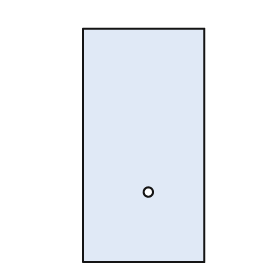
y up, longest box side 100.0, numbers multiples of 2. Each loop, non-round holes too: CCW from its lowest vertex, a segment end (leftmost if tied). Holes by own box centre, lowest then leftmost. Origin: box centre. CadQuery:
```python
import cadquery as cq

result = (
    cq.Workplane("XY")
    .moveTo(-26.0, -50.0)
    .lineTo(26.0, -50.0)
    .lineTo(26.0, 50.0)
    .lineTo(-26.0, 50.0)
    .close()
    .moveTo(2.0, -20.0)
    .circle(2.0)
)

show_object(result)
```